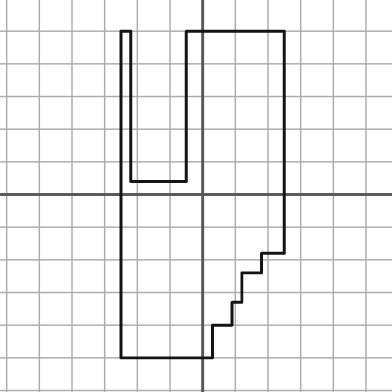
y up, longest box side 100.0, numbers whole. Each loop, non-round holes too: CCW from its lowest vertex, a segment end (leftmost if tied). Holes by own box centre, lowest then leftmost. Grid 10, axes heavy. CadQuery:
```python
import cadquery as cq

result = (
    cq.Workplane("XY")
    .moveTo(-25.0, -50.0)
    .lineTo(3.0, -50.0)
    .lineTo(3.0, -40.0)
    .lineTo(9.0, -40.0)
    .lineTo(9.0, -33.0)
    .lineTo(12.0, -33.0)
    .lineTo(12.0, -24.0)
    .lineTo(18.0, -24.0)
    .lineTo(18.0, -18.0)
    .lineTo(25.0, -18.0)
    .lineTo(25.0, 50.0)
    .lineTo(-5.0, 50.0)
    .lineTo(-5.0, 4.0)
    .lineTo(-22.0, 4.0)
    .lineTo(-22.0, 50.0)
    .lineTo(-25.0, 50.0)
    .close()
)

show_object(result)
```